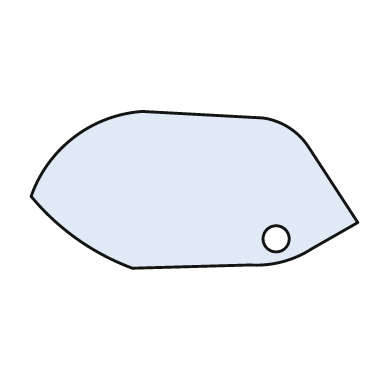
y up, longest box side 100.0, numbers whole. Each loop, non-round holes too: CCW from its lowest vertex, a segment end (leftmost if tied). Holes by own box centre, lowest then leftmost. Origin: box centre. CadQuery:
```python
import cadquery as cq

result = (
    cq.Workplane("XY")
    .moveTo(-19.0, -24.0)
    .lineTo(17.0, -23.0)
    .threePointArc((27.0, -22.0), (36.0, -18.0))
    .lineTo(50.0, -10.0)
    .lineTo(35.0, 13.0)
    .threePointArc((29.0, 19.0), (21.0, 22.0))
    .lineTo(-16.0, 24.0)
    .threePointArc((-37.0, 16.0), (-50.0, -2.0))
    .threePointArc((-36.0, -15.0), (-19.0, -24.0))
    .close()
    .moveTo(25.0, -15.0)
    .circle(4.0)
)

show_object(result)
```